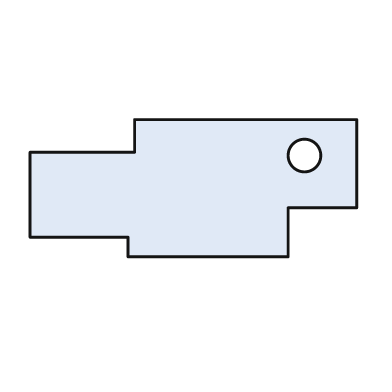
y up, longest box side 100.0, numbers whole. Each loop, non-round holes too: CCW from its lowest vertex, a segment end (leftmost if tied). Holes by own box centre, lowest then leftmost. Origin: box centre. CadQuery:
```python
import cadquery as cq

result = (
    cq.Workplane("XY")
    .moveTo(-20.0, -21.0)
    .lineTo(29.0, -21.0)
    .lineTo(29.0, -6.0)
    .lineTo(50.0, -6.0)
    .lineTo(50.0, 21.0)
    .lineTo(-18.0, 21.0)
    .lineTo(-18.0, 11.0)
    .lineTo(-50.0, 11.0)
    .lineTo(-50.0, -15.0)
    .lineTo(-20.0, -15.0)
    .close()
    .moveTo(34.0, 10.0)
    .circle(5.0)
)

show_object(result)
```